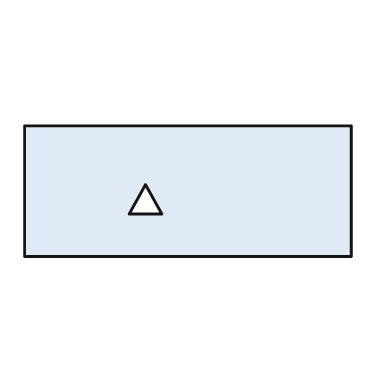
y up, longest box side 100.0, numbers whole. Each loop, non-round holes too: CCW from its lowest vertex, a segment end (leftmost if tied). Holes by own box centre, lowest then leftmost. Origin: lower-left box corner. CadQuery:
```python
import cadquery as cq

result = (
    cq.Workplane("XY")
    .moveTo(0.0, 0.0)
    .lineTo(100.0, 0.0)
    .lineTo(100.0, 40.0)
    .lineTo(0.0, 40.0)
    .close()
    .moveTo(32.0, 13.0)
    .lineTo(42.0, 13.0)
    .lineTo(37.0, 22.0)
    .close()
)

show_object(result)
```